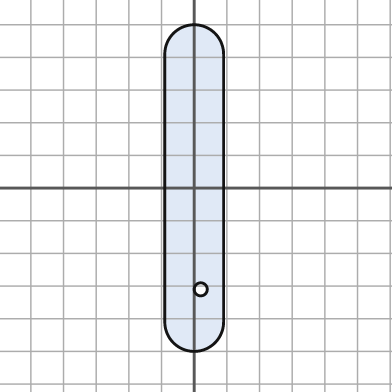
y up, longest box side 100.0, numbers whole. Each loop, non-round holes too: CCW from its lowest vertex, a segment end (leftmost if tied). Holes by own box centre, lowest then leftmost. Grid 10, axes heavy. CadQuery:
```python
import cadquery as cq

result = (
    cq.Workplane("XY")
    .moveTo(-9.0, -41.0)
    .threePointArc((0.0, -50.0), (9.0, -41.0))
    .lineTo(9.0, 41.0)
    .threePointArc((0.0, 50.0), (-9.0, 41.0))
    .close()
    .moveTo(2.0, -31.0)
    .circle(2.0)
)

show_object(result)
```